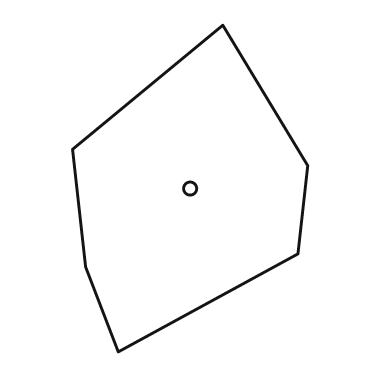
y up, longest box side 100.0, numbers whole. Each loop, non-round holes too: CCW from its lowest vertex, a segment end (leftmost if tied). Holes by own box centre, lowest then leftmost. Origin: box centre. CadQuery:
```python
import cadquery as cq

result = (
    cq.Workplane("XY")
    .moveTo(-22.0, -50.0)
    .lineTo(33.0, -20.0)
    .lineTo(36.0, 7.0)
    .lineTo(10.0, 50.0)
    .lineTo(-36.0, 12.0)
    .lineTo(-32.0, -24.0)
    .close()
    .moveTo(0.0, 0.0)
    .circle(2.0)
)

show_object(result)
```